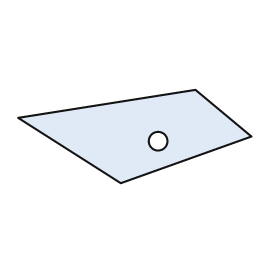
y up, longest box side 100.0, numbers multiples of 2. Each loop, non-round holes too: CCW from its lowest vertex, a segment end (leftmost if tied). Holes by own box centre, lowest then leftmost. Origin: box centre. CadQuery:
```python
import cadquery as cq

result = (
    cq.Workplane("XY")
    .moveTo(-6.0, -20.0)
    .lineTo(50.0, 0.0)
    .lineTo(26.0, 20.0)
    .lineTo(-50.0, 8.0)
    .close()
    .moveTo(10.0, -2.0)
    .circle(4.0)
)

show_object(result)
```